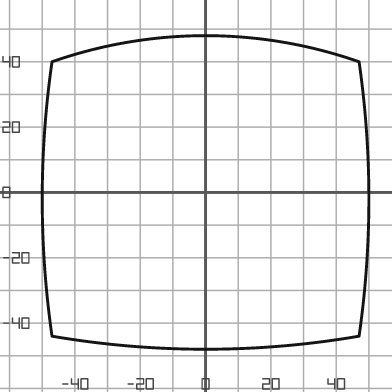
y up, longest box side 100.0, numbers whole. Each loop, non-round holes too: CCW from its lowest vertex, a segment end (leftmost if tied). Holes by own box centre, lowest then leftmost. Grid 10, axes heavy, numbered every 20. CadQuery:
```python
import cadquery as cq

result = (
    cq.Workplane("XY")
    .moveTo(-47.0, -44.0)
    .threePointArc((0.0, -48.0), (47.0, -44.0))
    .threePointArc((50.0, -2.0), (47.0, 40.0))
    .threePointArc((0.0, 48.0), (-47.0, 40.0))
    .threePointArc((-50.0, -2.0), (-47.0, -44.0))
    .close()
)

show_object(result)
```